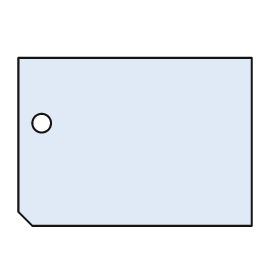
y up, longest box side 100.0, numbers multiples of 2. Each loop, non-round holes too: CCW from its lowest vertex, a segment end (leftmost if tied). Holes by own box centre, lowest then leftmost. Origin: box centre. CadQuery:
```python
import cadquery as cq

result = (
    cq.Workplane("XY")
    .moveTo(-44.0, -36.0)
    .lineTo(50.0, -36.0)
    .lineTo(50.0, 36.0)
    .lineTo(-50.0, 36.0)
    .lineTo(-50.0, -30.0)
    .close()
    .moveTo(-40.0, 8.0)
    .circle(4.0)
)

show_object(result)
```